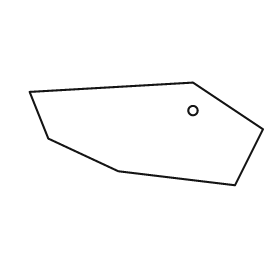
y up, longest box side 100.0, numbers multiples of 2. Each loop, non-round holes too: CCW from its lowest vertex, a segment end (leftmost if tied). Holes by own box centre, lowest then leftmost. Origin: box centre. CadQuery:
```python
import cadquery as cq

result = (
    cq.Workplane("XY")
    .moveTo(38.0, -22.0)
    .lineTo(50.0, 2.0)
    .lineTo(20.0, 22.0)
    .lineTo(-50.0, 18.0)
    .lineTo(-42.0, -2.0)
    .lineTo(-12.0, -16.0)
    .close()
    .moveTo(20.0, 10.0)
    .circle(2.0)
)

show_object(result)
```